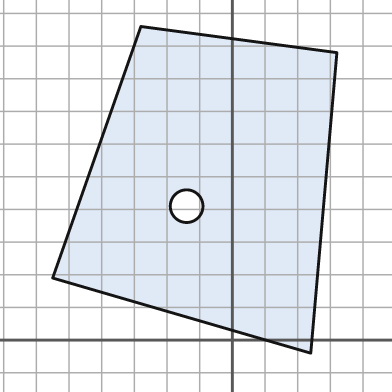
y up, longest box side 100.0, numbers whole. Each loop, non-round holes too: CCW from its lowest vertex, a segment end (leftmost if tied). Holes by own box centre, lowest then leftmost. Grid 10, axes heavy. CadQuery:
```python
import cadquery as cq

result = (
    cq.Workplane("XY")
    .moveTo(24.0, -4.0)
    .lineTo(32.0, 88.0)
    .lineTo(-28.0, 96.0)
    .lineTo(-55.0, 19.0)
    .close()
    .moveTo(-14.0, 41.0)
    .circle(5.0)
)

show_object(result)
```